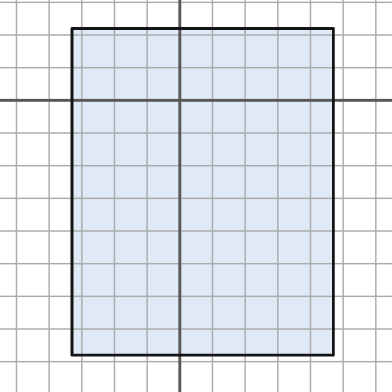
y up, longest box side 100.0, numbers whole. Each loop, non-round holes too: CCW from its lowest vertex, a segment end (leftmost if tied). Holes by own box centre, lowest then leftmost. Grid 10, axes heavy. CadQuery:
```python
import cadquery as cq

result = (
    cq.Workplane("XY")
    .moveTo(-33.0, -78.0)
    .lineTo(47.0, -78.0)
    .lineTo(47.0, 22.0)
    .lineTo(-33.0, 22.0)
    .close()
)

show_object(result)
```